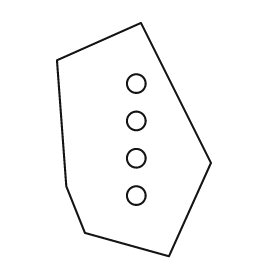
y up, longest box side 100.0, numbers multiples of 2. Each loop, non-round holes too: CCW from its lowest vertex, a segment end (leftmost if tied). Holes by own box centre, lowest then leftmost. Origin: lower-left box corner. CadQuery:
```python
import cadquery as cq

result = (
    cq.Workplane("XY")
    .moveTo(48.0, 0.0)
    .lineTo(66.0, 40.0)
    .lineTo(36.0, 100.0)
    .lineTo(0.0, 84.0)
    .lineTo(4.0, 30.0)
    .lineTo(12.0, 10.0)
    .close()
    .moveTo(34.0, 26.0)
    .circle(4.0)
    .moveTo(34.0, 42.0)
    .circle(4.0)
    .moveTo(34.0, 58.0)
    .circle(4.0)
    .moveTo(34.0, 74.0)
    .circle(4.0)
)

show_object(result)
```